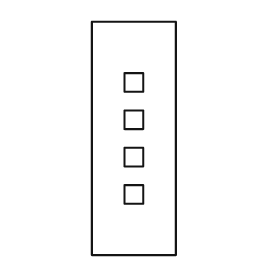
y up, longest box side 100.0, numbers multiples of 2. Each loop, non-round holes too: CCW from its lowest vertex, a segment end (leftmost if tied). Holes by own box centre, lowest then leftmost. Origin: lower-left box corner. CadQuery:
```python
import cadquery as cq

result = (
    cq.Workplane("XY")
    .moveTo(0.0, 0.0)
    .lineTo(36.0, 0.0)
    .lineTo(36.0, 100.0)
    .lineTo(0.0, 100.0)
    .close()
    .moveTo(14.0, 22.0)
    .lineTo(22.0, 22.0)
    .lineTo(22.0, 30.0)
    .lineTo(14.0, 30.0)
    .close()
    .moveTo(14.0, 38.0)
    .lineTo(22.0, 38.0)
    .lineTo(22.0, 46.0)
    .lineTo(14.0, 46.0)
    .close()
    .moveTo(14.0, 54.0)
    .lineTo(22.0, 54.0)
    .lineTo(22.0, 62.0)
    .lineTo(14.0, 62.0)
    .close()
    .moveTo(14.0, 70.0)
    .lineTo(22.0, 70.0)
    .lineTo(22.0, 78.0)
    .lineTo(14.0, 78.0)
    .close()
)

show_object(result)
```